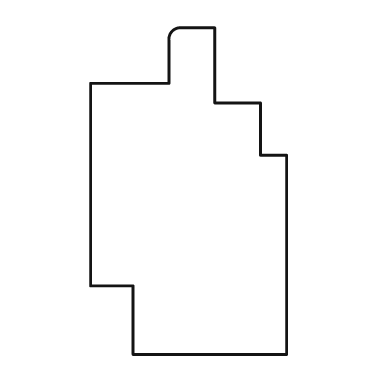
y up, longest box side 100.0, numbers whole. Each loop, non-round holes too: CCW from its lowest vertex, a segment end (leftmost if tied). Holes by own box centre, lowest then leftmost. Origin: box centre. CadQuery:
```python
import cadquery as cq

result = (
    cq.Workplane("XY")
    .moveTo(-17.0, -50.0)
    .lineTo(30.0, -50.0)
    .lineTo(30.0, 11.0)
    .lineTo(22.0, 11.0)
    .lineTo(22.0, 27.0)
    .lineTo(8.0, 27.0)
    .lineTo(8.0, 50.0)
    .lineTo(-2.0, 50.0)
    .threePointArc((-5.0, 49.0), (-6.0, 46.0))
    .lineTo(-6.0, 33.0)
    .lineTo(-30.0, 33.0)
    .lineTo(-30.0, -29.0)
    .lineTo(-17.0, -29.0)
    .close()
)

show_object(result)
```